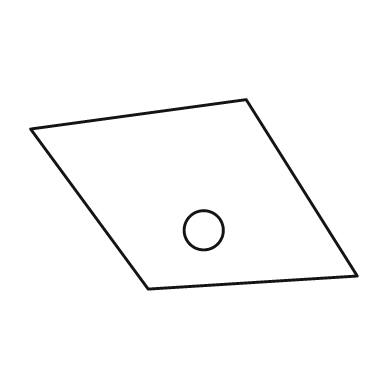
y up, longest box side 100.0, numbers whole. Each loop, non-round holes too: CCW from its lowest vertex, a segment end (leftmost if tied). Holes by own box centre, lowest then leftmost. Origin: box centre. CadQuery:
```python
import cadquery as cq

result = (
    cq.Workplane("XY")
    .moveTo(-14.0, -29.0)
    .lineTo(50.0, -25.0)
    .lineTo(16.0, 29.0)
    .lineTo(-50.0, 20.0)
    .close()
    .moveTo(3.0, -11.0)
    .circle(6.0)
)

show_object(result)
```